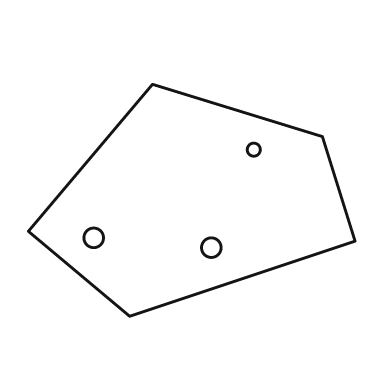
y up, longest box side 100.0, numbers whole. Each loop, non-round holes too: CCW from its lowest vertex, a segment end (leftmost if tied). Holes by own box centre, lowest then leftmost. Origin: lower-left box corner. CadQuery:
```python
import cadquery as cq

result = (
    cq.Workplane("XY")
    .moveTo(31.0, 0.0)
    .lineTo(100.0, 23.0)
    .lineTo(90.0, 55.0)
    .lineTo(38.0, 71.0)
    .lineTo(0.0, 26.0)
    .close()
    .moveTo(56.0, 21.0)
    .circle(3.0)
    .moveTo(20.0, 24.0)
    .circle(3.0)
    .moveTo(69.0, 51.0)
    .circle(2.0)
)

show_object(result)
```